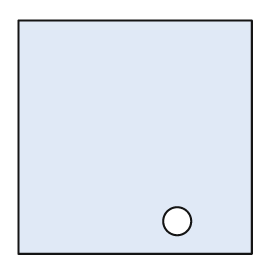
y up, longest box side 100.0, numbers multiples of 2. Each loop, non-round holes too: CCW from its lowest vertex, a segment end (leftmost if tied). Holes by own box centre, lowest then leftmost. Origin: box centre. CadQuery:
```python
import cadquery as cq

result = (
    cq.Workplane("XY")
    .moveTo(-50.0, -50.0)
    .lineTo(50.0, -50.0)
    .lineTo(50.0, 50.0)
    .lineTo(-50.0, 50.0)
    .close()
    .moveTo(18.0, -36.0)
    .circle(6.0)
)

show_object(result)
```